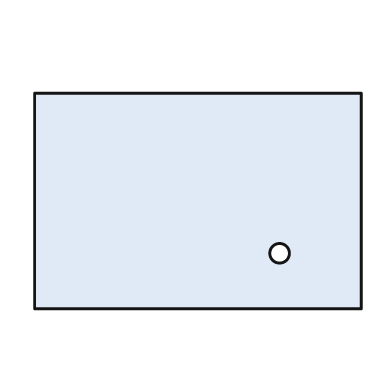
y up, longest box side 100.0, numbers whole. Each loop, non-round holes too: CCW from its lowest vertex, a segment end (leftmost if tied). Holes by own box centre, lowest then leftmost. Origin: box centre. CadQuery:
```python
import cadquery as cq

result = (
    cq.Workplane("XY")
    .moveTo(-50.0, -33.0)
    .lineTo(50.0, -33.0)
    .lineTo(50.0, 33.0)
    .lineTo(-50.0, 33.0)
    .close()
    .moveTo(25.0, -16.0)
    .circle(3.0)
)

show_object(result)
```